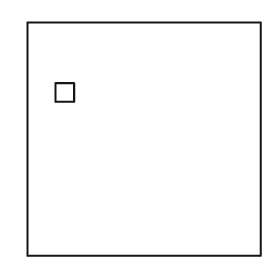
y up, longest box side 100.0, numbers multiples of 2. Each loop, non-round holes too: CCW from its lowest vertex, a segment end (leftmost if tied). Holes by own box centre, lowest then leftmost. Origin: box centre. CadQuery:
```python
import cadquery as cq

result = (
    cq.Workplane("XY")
    .moveTo(-50.0, -50.0)
    .lineTo(50.0, -50.0)
    .lineTo(50.0, 50.0)
    .lineTo(-50.0, 50.0)
    .close()
    .moveTo(-38.0, 16.0)
    .lineTo(-30.0, 16.0)
    .lineTo(-30.0, 24.0)
    .lineTo(-38.0, 24.0)
    .close()
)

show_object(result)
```